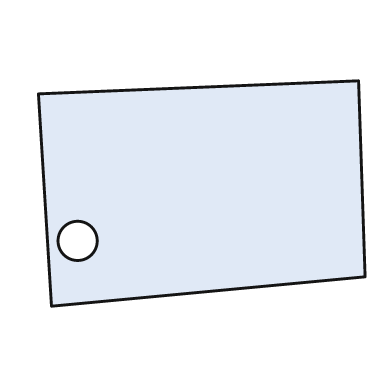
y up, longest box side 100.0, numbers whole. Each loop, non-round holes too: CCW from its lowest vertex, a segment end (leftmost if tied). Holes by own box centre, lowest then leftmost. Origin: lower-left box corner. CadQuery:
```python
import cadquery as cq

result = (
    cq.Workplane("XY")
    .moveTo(4.0, 0.0)
    .lineTo(100.0, 9.0)
    .lineTo(98.0, 69.0)
    .lineTo(0.0, 65.0)
    .close()
    .moveTo(12.0, 20.0)
    .circle(6.0)
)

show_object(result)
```